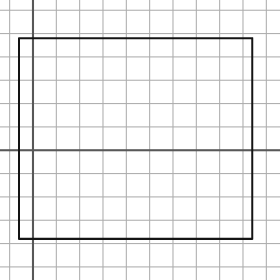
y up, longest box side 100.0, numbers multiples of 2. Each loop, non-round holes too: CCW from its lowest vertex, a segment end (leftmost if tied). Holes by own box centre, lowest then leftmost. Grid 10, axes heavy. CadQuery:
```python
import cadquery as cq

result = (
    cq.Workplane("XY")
    .moveTo(-6.0, -38.0)
    .lineTo(94.0, -38.0)
    .lineTo(94.0, 48.0)
    .lineTo(-6.0, 48.0)
    .close()
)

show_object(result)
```